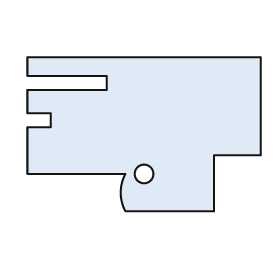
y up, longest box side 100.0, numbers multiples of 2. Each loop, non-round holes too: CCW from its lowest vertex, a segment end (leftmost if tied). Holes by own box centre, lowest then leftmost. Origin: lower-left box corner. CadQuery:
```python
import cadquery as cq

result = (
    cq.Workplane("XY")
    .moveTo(42.0, 0.0)
    .lineTo(80.0, 0.0)
    .lineTo(80.0, 24.0)
    .lineTo(100.0, 24.0)
    .lineTo(100.0, 66.0)
    .lineTo(0.0, 66.0)
    .lineTo(0.0, 58.0)
    .lineTo(34.0, 58.0)
    .lineTo(34.0, 52.0)
    .lineTo(0.0, 52.0)
    .lineTo(0.0, 42.0)
    .lineTo(10.0, 42.0)
    .lineTo(10.0, 36.0)
    .lineTo(0.0, 36.0)
    .lineTo(0.0, 16.0)
    .lineTo(42.0, 16.0)
    .threePointArc((40.0, 8.0), (42.0, 0.0))
    .close()
    .moveTo(50.0, 16.0)
    .circle(4.0)
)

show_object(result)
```